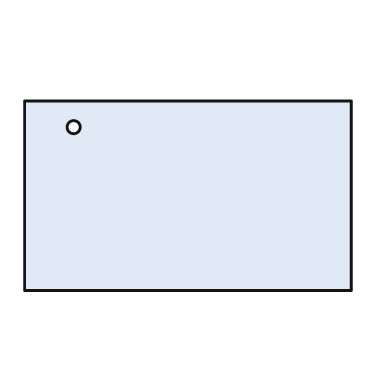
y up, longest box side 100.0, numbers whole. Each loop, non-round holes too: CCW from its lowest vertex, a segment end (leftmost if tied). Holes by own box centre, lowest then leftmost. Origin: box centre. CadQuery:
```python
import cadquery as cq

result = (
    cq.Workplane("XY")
    .moveTo(-50.0, -29.0)
    .lineTo(50.0, -29.0)
    .lineTo(50.0, 29.0)
    .lineTo(-50.0, 29.0)
    .close()
    .moveTo(-35.0, 21.0)
    .circle(2.0)
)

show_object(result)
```